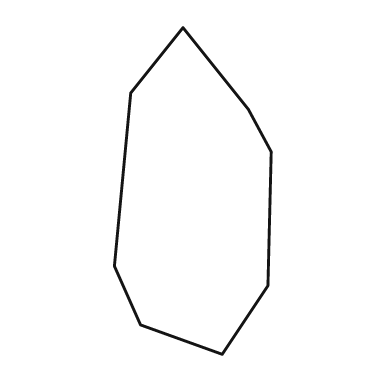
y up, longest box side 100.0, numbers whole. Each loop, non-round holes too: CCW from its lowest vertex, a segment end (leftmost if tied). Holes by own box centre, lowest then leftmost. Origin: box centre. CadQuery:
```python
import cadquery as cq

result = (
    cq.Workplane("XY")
    .moveTo(9.0, -50.0)
    .lineTo(23.0, -29.0)
    .lineTo(24.0, 12.0)
    .lineTo(17.0, 25.0)
    .lineTo(-3.0, 50.0)
    .lineTo(-19.0, 30.0)
    .lineTo(-24.0, -23.0)
    .lineTo(-16.0, -41.0)
    .close()
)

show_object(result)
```